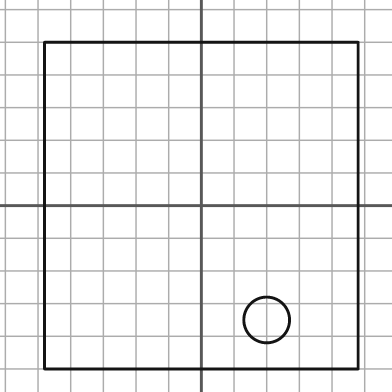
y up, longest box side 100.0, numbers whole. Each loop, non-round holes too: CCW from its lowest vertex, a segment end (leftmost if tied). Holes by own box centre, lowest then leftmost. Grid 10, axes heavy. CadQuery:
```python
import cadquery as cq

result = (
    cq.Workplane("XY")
    .moveTo(-48.0, -50.0)
    .lineTo(48.0, -50.0)
    .lineTo(48.0, 50.0)
    .lineTo(-48.0, 50.0)
    .close()
    .moveTo(20.0, -35.0)
    .circle(7.0)
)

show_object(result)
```